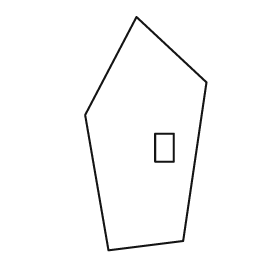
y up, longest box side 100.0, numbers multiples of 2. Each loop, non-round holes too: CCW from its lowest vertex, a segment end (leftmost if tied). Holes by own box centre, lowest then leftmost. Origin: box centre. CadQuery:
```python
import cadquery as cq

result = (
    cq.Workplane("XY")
    .moveTo(-16.0, -50.0)
    .lineTo(16.0, -46.0)
    .lineTo(26.0, 22.0)
    .lineTo(-4.0, 50.0)
    .lineTo(-26.0, 8.0)
    .close()
    .moveTo(4.0, -12.0)
    .lineTo(12.0, -12.0)
    .lineTo(12.0, 0.0)
    .lineTo(4.0, 0.0)
    .close()
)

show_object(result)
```